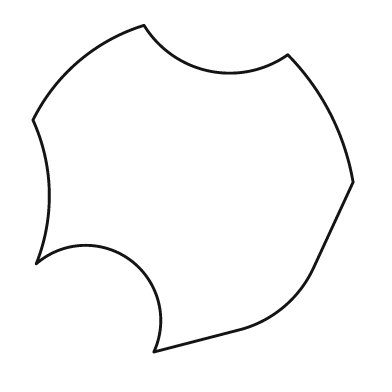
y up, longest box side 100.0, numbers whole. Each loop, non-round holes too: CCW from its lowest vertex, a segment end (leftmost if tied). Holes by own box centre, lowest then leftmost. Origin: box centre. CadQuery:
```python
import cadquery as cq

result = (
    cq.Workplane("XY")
    .moveTo(-12.0, -50.0)
    .lineTo(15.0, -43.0)
    .threePointArc((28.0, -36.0), (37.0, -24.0))
    .lineTo(49.0, 2.0)
    .threePointArc((42.0, 23.0), (29.0, 41.0))
    .threePointArc((5.0, 36.0), (-15.0, 50.0))
    .threePointArc((-35.0, 39.0), (-49.0, 21.0))
    .threePointArc((-44.0, -1.0), (-48.0, -23.0))
    .threePointArc((-19.0, -22.0), (-12.0, -50.0))
    .close()
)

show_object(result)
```